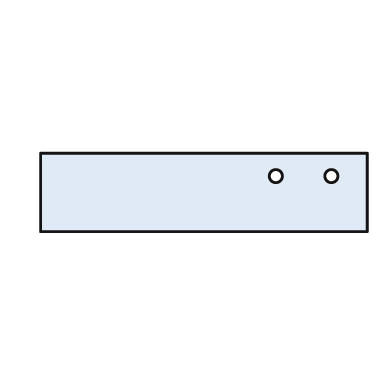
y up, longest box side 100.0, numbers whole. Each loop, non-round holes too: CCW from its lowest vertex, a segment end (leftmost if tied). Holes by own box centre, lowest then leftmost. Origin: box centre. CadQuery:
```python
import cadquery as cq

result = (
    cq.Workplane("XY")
    .moveTo(-50.0, -12.0)
    .lineTo(50.0, -12.0)
    .lineTo(50.0, 12.0)
    .lineTo(-50.0, 12.0)
    .close()
    .moveTo(22.0, 5.0)
    .circle(2.0)
    .moveTo(39.0, 5.0)
    .circle(2.0)
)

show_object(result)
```